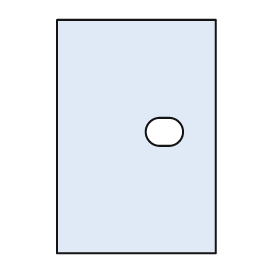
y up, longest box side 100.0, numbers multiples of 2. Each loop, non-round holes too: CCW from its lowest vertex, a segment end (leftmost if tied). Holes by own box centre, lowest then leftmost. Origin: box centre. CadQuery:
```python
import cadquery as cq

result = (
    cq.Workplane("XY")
    .moveTo(-34.0, -50.0)
    .lineTo(34.0, -50.0)
    .lineTo(34.0, 50.0)
    .lineTo(-34.0, 50.0)
    .close()
    .moveTo(10.0, -4.0)
    .lineTo(14.0, -4.0)
    .threePointArc((20.0, 2.0), (14.0, 8.0))
    .lineTo(10.0, 8.0)
    .threePointArc((4.0, 2.0), (10.0, -4.0))
    .close()
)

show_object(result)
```